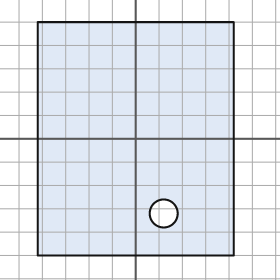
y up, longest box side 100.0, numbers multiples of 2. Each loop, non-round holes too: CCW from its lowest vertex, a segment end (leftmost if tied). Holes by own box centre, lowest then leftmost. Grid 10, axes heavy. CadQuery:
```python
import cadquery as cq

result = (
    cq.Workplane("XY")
    .moveTo(-42.0, -50.0)
    .lineTo(42.0, -50.0)
    .lineTo(42.0, 50.0)
    .lineTo(-42.0, 50.0)
    .close()
    .moveTo(12.0, -32.0)
    .circle(6.0)
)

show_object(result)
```